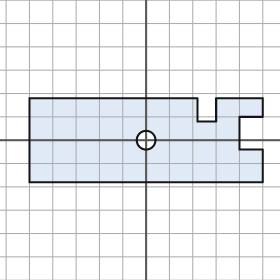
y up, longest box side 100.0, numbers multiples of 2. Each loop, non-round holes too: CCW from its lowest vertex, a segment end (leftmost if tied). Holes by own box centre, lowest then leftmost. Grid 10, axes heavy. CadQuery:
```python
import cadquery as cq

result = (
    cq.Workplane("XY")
    .moveTo(-50.0, -18.0)
    .lineTo(50.0, -18.0)
    .lineTo(50.0, -4.0)
    .lineTo(40.0, -4.0)
    .lineTo(40.0, 10.0)
    .lineTo(50.0, 10.0)
    .lineTo(50.0, 18.0)
    .lineTo(30.0, 18.0)
    .lineTo(30.0, 8.0)
    .lineTo(22.0, 8.0)
    .lineTo(22.0, 18.0)
    .lineTo(-50.0, 18.0)
    .close()
    .moveTo(0.0, 0.0)
    .circle(4.0)
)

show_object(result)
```